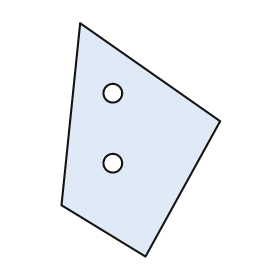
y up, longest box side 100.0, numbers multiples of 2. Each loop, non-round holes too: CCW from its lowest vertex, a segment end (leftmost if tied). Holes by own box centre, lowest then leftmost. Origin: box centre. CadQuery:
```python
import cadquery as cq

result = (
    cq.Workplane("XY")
    .moveTo(2.0, -50.0)
    .lineTo(34.0, 8.0)
    .lineTo(-26.0, 50.0)
    .lineTo(-34.0, -28.0)
    .close()
    .moveTo(-12.0, -10.0)
    .circle(4.0)
    .moveTo(-12.0, 20.0)
    .circle(4.0)
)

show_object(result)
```